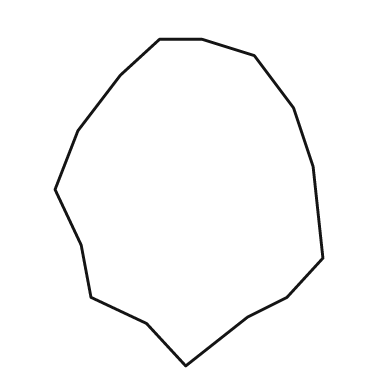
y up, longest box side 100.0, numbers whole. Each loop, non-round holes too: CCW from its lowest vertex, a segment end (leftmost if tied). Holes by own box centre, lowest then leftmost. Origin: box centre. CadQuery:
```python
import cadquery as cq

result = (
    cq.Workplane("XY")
    .moveTo(-1.0, -50.0)
    .lineTo(18.0, -35.0)
    .lineTo(30.0, -29.0)
    .lineTo(41.0, -17.0)
    .lineTo(38.0, 11.0)
    .lineTo(32.0, 29.0)
    .lineTo(20.0, 45.0)
    .lineTo(4.0, 50.0)
    .lineTo(-9.0, 50.0)
    .lineTo(-21.0, 39.0)
    .lineTo(-34.0, 22.0)
    .lineTo(-41.0, 4.0)
    .lineTo(-33.0, -13.0)
    .lineTo(-30.0, -29.0)
    .lineTo(-13.0, -37.0)
    .close()
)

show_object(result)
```